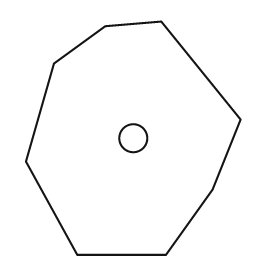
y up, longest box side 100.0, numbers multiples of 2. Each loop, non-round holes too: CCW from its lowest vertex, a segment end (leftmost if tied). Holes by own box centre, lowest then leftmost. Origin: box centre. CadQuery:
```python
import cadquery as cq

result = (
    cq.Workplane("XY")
    .moveTo(-24.0, -50.0)
    .lineTo(14.0, -50.0)
    .lineTo(34.0, -22.0)
    .lineTo(46.0, 8.0)
    .lineTo(12.0, 50.0)
    .lineTo(-12.0, 48.0)
    .lineTo(-34.0, 32.0)
    .lineTo(-46.0, -10.0)
    .close()
    .moveTo(0.0, 0.0)
    .circle(6.0)
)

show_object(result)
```